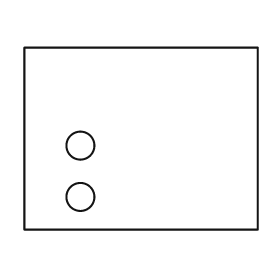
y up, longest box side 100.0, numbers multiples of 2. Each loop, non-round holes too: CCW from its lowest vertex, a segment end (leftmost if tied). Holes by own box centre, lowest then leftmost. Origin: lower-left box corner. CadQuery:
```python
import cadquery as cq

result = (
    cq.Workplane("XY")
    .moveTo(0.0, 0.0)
    .lineTo(100.0, 0.0)
    .lineTo(100.0, 78.0)
    .lineTo(0.0, 78.0)
    .close()
    .moveTo(24.0, 14.0)
    .circle(6.0)
    .moveTo(24.0, 36.0)
    .circle(6.0)
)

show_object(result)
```